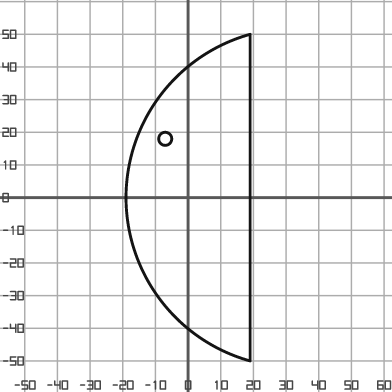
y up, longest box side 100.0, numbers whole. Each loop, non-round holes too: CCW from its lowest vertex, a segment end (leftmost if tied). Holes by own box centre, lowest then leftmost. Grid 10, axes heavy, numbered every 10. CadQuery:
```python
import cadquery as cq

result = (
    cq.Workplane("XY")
    .moveTo(19.0, -50.0)
    .lineTo(19.0, 50.0)
    .threePointArc((-19.0, 0.0), (19.0, -50.0))
    .close()
    .moveTo(-7.0, 18.0)
    .circle(2.0)
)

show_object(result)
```